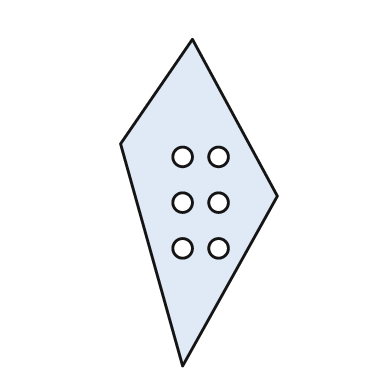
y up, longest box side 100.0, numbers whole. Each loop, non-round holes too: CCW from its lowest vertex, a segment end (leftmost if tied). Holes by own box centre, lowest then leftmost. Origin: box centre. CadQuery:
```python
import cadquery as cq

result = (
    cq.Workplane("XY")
    .moveTo(-5.0, -50.0)
    .lineTo(24.0, 2.0)
    .lineTo(-2.0, 50.0)
    .lineTo(-24.0, 18.0)
    .close()
    .moveTo(-5.0, -14.0)
    .circle(3.0)
    .moveTo(6.0, -14.0)
    .circle(3.0)
    .moveTo(-5.0, 0.0)
    .circle(3.0)
    .moveTo(6.0, 0.0)
    .circle(3.0)
    .moveTo(-5.0, 14.0)
    .circle(3.0)
    .moveTo(6.0, 14.0)
    .circle(3.0)
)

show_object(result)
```